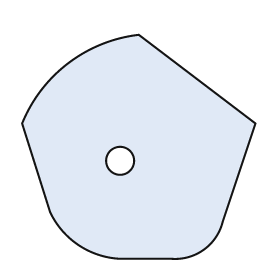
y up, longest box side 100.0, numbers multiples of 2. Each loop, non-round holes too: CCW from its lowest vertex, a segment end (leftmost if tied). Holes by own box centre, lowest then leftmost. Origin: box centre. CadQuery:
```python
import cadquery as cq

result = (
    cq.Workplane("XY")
    .moveTo(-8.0, -48.0)
    .lineTo(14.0, -48.0)
    .threePointArc((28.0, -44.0), (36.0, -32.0))
    .lineTo(50.0, 10.0)
    .lineTo(0.0, 48.0)
    .threePointArc((-30.0, 36.0), (-50.0, 10.0))
    .lineTo(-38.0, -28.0)
    .threePointArc((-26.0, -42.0), (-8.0, -48.0))
    .close()
    .moveTo(-8.0, -6.0)
    .circle(6.0)
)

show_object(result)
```